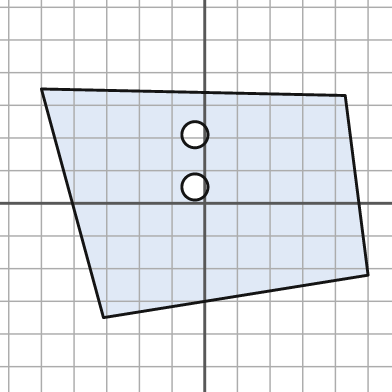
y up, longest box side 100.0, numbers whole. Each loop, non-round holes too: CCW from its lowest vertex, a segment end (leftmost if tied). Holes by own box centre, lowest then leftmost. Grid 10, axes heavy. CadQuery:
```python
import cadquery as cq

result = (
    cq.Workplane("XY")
    .moveTo(-31.0, -35.0)
    .lineTo(50.0, -22.0)
    .lineTo(43.0, 33.0)
    .lineTo(-50.0, 35.0)
    .close()
    .moveTo(-3.0, 5.0)
    .circle(4.0)
    .moveTo(-3.0, 21.0)
    .circle(4.0)
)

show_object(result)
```